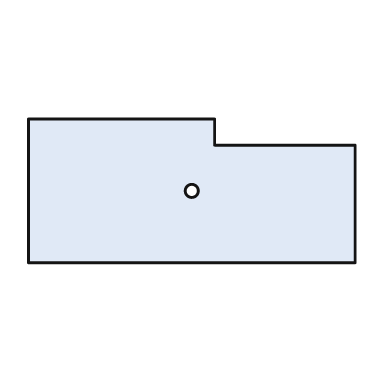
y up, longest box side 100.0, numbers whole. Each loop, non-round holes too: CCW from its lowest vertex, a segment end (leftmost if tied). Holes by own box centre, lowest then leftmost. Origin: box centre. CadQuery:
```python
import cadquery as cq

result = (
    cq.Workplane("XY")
    .moveTo(-50.0, -22.0)
    .lineTo(50.0, -22.0)
    .lineTo(50.0, 14.0)
    .lineTo(7.0, 14.0)
    .lineTo(7.0, 22.0)
    .lineTo(-50.0, 22.0)
    .close()
    .moveTo(0.0, 0.0)
    .circle(2.0)
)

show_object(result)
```